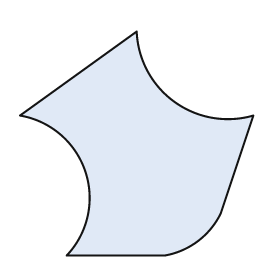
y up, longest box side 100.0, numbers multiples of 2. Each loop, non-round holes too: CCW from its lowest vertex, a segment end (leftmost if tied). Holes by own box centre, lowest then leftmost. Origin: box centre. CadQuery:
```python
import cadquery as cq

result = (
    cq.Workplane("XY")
    .moveTo(-30.0, -48.0)
    .lineTo(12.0, -48.0)
    .threePointArc((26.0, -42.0), (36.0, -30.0))
    .lineTo(50.0, 12.0)
    .threePointArc((16.0, 18.0), (0.0, 48.0))
    .lineTo(-50.0, 12.0)
    .threePointArc((-22.0, -12.0), (-30.0, -48.0))
    .close()
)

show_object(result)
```